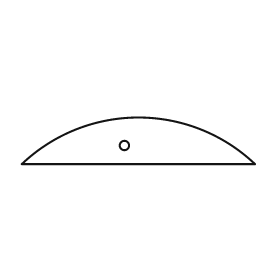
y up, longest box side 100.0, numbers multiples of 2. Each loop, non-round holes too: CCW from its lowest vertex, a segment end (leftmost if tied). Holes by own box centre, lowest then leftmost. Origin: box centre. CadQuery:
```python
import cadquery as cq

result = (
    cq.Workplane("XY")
    .moveTo(-50.0, -10.0)
    .lineTo(50.0, -10.0)
    .threePointArc((0.0, 10.0), (-50.0, -10.0))
    .close()
    .moveTo(-6.0, -2.0)
    .circle(2.0)
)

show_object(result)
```